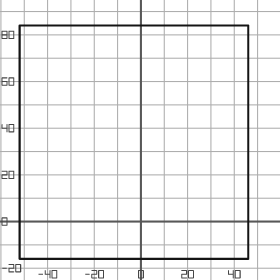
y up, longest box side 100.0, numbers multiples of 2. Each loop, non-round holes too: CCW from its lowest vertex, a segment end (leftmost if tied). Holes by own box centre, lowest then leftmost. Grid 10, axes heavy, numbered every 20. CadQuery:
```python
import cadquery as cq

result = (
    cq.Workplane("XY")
    .moveTo(-52.0, -16.0)
    .lineTo(46.0, -16.0)
    .lineTo(46.0, 84.0)
    .lineTo(-52.0, 84.0)
    .close()
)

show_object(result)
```